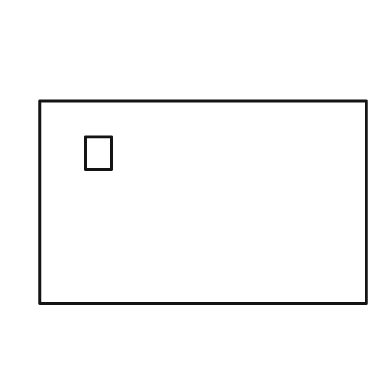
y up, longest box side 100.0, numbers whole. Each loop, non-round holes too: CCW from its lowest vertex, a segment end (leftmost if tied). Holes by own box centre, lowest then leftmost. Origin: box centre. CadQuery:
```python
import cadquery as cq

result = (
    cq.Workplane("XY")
    .moveTo(-50.0, -31.0)
    .lineTo(50.0, -31.0)
    .lineTo(50.0, 31.0)
    .lineTo(-50.0, 31.0)
    .close()
    .moveTo(-36.0, 10.0)
    .lineTo(-28.0, 10.0)
    .lineTo(-28.0, 20.0)
    .lineTo(-36.0, 20.0)
    .close()
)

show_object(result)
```